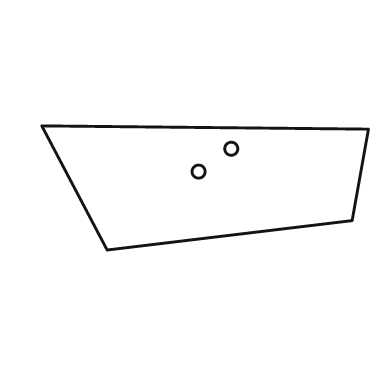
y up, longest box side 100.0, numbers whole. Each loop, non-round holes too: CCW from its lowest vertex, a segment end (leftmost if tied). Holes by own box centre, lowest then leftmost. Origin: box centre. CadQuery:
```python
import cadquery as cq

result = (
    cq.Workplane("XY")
    .moveTo(-30.0, -19.0)
    .lineTo(45.0, -10.0)
    .lineTo(50.0, 18.0)
    .lineTo(-50.0, 19.0)
    .close()
    .moveTo(-2.0, 5.0)
    .circle(2.0)
    .moveTo(8.0, 12.0)
    .circle(2.0)
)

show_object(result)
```